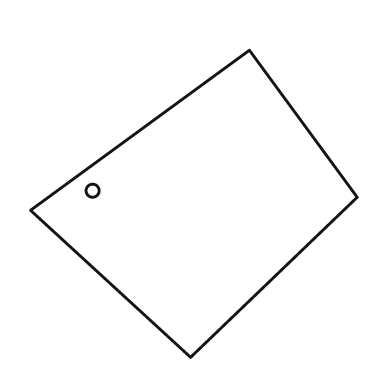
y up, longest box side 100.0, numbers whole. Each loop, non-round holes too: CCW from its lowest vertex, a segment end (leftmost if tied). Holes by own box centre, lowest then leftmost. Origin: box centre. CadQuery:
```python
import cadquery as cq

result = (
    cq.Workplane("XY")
    .moveTo(-1.0, -47.0)
    .lineTo(50.0, 2.0)
    .lineTo(17.0, 47.0)
    .lineTo(-50.0, -2.0)
    .close()
    .moveTo(-31.0, 4.0)
    .circle(2.0)
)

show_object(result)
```